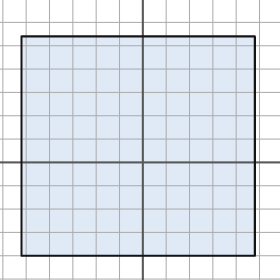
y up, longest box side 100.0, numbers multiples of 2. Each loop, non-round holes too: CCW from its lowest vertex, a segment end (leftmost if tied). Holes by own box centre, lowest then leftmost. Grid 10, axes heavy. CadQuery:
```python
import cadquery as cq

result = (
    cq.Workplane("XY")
    .moveTo(-52.0, -40.0)
    .lineTo(48.0, -40.0)
    .lineTo(48.0, 54.0)
    .lineTo(-52.0, 54.0)
    .close()
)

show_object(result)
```